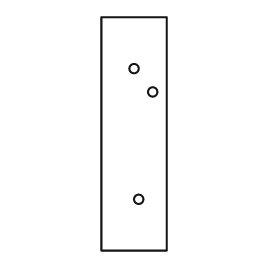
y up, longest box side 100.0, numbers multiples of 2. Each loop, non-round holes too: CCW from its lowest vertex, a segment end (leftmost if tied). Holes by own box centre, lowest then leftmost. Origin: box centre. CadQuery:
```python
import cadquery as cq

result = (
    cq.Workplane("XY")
    .moveTo(-14.0, -50.0)
    .lineTo(14.0, -50.0)
    .lineTo(14.0, 50.0)
    .lineTo(-14.0, 50.0)
    .close()
    .moveTo(2.0, -28.0)
    .circle(2.0)
    .moveTo(8.0, 18.0)
    .circle(2.0)
    .moveTo(0.0, 28.0)
    .circle(2.0)
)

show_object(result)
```